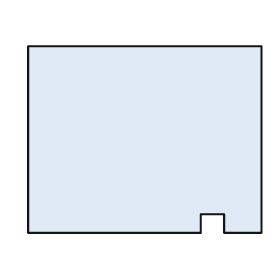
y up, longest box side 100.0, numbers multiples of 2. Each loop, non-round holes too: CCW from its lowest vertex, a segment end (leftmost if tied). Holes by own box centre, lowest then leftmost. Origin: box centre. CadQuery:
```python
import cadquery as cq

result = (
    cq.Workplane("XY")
    .moveTo(-50.0, -40.0)
    .lineTo(24.0, -40.0)
    .lineTo(24.0, -32.0)
    .lineTo(34.0, -32.0)
    .lineTo(34.0, -40.0)
    .lineTo(50.0, -40.0)
    .lineTo(50.0, 40.0)
    .lineTo(-50.0, 40.0)
    .close()
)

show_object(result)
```